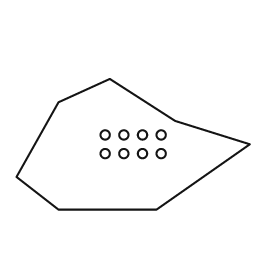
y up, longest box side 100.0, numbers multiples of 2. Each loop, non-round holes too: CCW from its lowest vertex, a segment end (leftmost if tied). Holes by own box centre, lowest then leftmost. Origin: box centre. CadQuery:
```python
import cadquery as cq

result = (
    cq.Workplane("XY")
    .moveTo(-32.0, -28.0)
    .lineTo(10.0, -28.0)
    .lineTo(50.0, 0.0)
    .lineTo(18.0, 10.0)
    .lineTo(-10.0, 28.0)
    .lineTo(-32.0, 18.0)
    .lineTo(-50.0, -14.0)
    .close()
    .moveTo(-12.0, -4.0)
    .circle(2.0)
    .moveTo(-4.0, -4.0)
    .circle(2.0)
    .moveTo(4.0, -4.0)
    .circle(2.0)
    .moveTo(12.0, -4.0)
    .circle(2.0)
    .moveTo(-12.0, 4.0)
    .circle(2.0)
    .moveTo(-4.0, 4.0)
    .circle(2.0)
    .moveTo(4.0, 4.0)
    .circle(2.0)
    .moveTo(12.0, 4.0)
    .circle(2.0)
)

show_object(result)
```